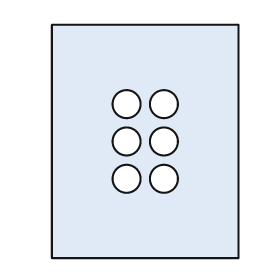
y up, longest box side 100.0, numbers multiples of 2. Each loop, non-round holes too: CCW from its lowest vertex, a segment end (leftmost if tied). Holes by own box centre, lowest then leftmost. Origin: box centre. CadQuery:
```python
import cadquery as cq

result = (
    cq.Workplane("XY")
    .moveTo(-40.0, -50.0)
    .lineTo(40.0, -50.0)
    .lineTo(40.0, 50.0)
    .lineTo(-40.0, 50.0)
    .close()
    .moveTo(-8.0, -16.0)
    .circle(6.0)
    .moveTo(8.0, -16.0)
    .circle(6.0)
    .moveTo(-8.0, 0.0)
    .circle(6.0)
    .moveTo(8.0, 0.0)
    .circle(6.0)
    .moveTo(-8.0, 16.0)
    .circle(6.0)
    .moveTo(8.0, 16.0)
    .circle(6.0)
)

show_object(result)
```